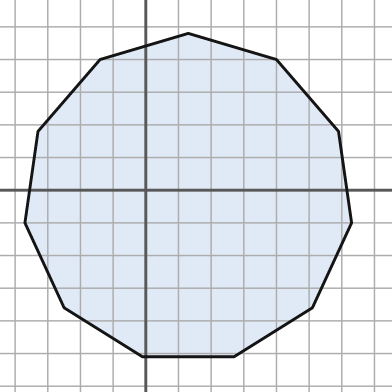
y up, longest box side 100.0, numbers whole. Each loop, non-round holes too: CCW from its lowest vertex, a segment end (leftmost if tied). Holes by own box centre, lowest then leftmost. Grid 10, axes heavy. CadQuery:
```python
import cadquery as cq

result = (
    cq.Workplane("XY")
    .moveTo(-1.0, -51.0)
    .lineTo(27.0, -51.0)
    .lineTo(51.0, -36.0)
    .lineTo(63.0, -10.0)
    .lineTo(59.0, 18.0)
    .lineTo(40.0, 40.0)
    .lineTo(13.0, 48.0)
    .lineTo(-14.0, 40.0)
    .lineTo(-33.0, 18.0)
    .lineTo(-37.0, -10.0)
    .lineTo(-25.0, -36.0)
    .close()
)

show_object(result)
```